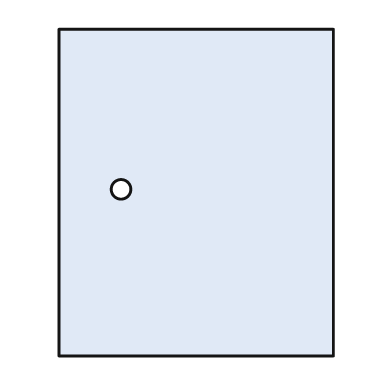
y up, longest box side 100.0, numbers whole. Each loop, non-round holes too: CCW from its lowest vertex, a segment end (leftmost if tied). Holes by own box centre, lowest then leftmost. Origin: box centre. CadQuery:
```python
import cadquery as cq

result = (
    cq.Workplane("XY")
    .moveTo(-42.0, -50.0)
    .lineTo(42.0, -50.0)
    .lineTo(42.0, 50.0)
    .lineTo(-42.0, 50.0)
    .close()
    .moveTo(-23.0, 1.0)
    .circle(3.0)
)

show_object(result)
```